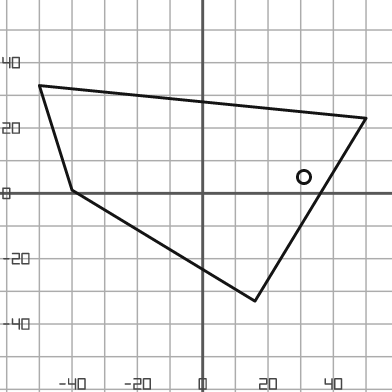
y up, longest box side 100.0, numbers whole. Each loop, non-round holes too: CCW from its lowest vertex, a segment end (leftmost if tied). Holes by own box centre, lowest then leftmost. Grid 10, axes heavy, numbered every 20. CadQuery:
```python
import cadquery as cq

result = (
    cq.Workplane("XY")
    .moveTo(16.0, -33.0)
    .lineTo(50.0, 23.0)
    .lineTo(-50.0, 33.0)
    .lineTo(-40.0, 1.0)
    .close()
    .moveTo(31.0, 5.0)
    .circle(2.0)
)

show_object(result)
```